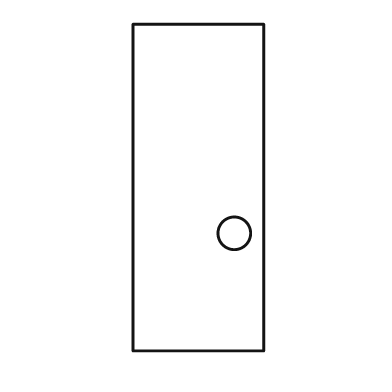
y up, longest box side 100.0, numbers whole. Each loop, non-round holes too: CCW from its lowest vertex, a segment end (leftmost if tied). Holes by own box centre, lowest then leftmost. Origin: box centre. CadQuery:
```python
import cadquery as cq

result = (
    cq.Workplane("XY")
    .moveTo(-20.0, -50.0)
    .lineTo(20.0, -50.0)
    .lineTo(20.0, 50.0)
    .lineTo(-20.0, 50.0)
    .close()
    .moveTo(11.0, -14.0)
    .circle(5.0)
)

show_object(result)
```